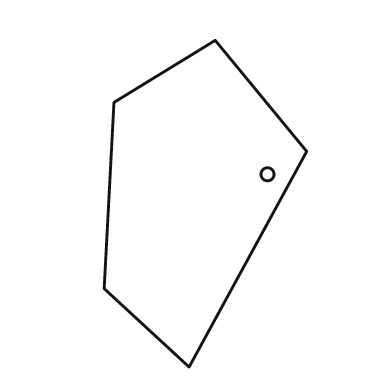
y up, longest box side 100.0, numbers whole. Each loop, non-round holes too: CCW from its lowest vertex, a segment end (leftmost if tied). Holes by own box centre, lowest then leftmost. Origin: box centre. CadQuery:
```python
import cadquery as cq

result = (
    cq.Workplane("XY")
    .moveTo(-5.0, -50.0)
    .lineTo(31.0, 16.0)
    .lineTo(3.0, 50.0)
    .lineTo(-28.0, 31.0)
    .lineTo(-31.0, -26.0)
    .close()
    .moveTo(19.0, 9.0)
    .circle(2.0)
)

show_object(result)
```